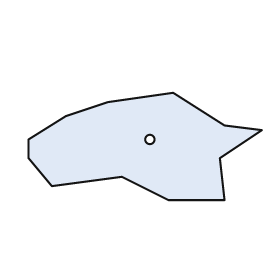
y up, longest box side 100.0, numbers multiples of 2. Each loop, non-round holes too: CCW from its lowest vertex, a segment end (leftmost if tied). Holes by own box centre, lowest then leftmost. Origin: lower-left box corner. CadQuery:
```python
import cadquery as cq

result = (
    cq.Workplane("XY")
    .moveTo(60.0, 0.0)
    .lineTo(84.0, 0.0)
    .lineTo(82.0, 18.0)
    .lineTo(100.0, 30.0)
    .lineTo(84.0, 32.0)
    .lineTo(62.0, 46.0)
    .lineTo(34.0, 42.0)
    .lineTo(16.0, 36.0)
    .lineTo(0.0, 26.0)
    .lineTo(0.0, 18.0)
    .lineTo(10.0, 6.0)
    .lineTo(40.0, 10.0)
    .close()
    .moveTo(52.0, 26.0)
    .circle(2.0)
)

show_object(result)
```